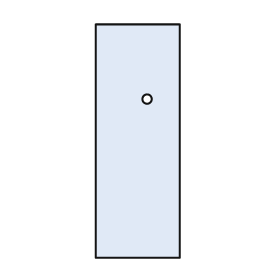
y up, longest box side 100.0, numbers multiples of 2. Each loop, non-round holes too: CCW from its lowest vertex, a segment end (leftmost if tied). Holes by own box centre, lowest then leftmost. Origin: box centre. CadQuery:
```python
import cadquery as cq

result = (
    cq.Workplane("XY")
    .moveTo(-18.0, -50.0)
    .lineTo(18.0, -50.0)
    .lineTo(18.0, 50.0)
    .lineTo(-18.0, 50.0)
    .close()
    .moveTo(4.0, 18.0)
    .circle(2.0)
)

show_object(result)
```